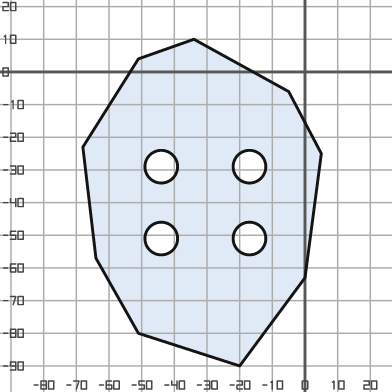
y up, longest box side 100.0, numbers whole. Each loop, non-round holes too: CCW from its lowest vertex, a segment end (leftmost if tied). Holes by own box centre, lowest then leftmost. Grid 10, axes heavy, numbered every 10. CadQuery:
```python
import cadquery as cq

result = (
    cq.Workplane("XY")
    .moveTo(-20.0, -90.0)
    .lineTo(0.0, -63.0)
    .lineTo(5.0, -25.0)
    .lineTo(-5.0, -6.0)
    .lineTo(-34.0, 10.0)
    .lineTo(-51.0, 4.0)
    .lineTo(-68.0, -23.0)
    .lineTo(-64.0, -57.0)
    .lineTo(-51.0, -80.0)
    .close()
    .moveTo(-44.0, -51.0)
    .circle(5.0)
    .moveTo(-17.0, -51.0)
    .circle(5.0)
    .moveTo(-44.0, -29.0)
    .circle(5.0)
    .moveTo(-17.0, -29.0)
    .circle(5.0)
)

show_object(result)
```